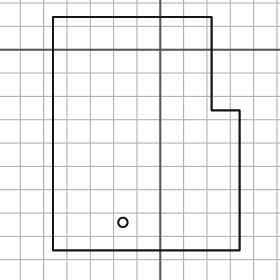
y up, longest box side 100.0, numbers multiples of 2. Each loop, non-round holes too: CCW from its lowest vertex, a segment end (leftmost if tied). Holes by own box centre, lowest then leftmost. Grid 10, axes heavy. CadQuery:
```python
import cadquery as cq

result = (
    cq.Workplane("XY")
    .moveTo(-46.0, -86.0)
    .lineTo(34.0, -86.0)
    .lineTo(34.0, -26.0)
    .lineTo(22.0, -26.0)
    .lineTo(22.0, 14.0)
    .lineTo(-46.0, 14.0)
    .close()
    .moveTo(-16.0, -74.0)
    .circle(2.0)
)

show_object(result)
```